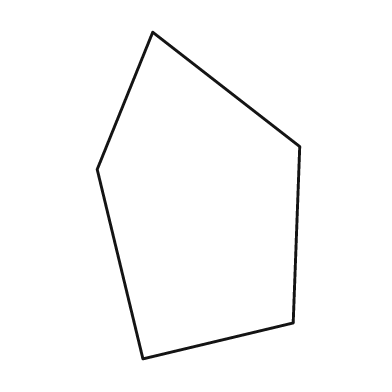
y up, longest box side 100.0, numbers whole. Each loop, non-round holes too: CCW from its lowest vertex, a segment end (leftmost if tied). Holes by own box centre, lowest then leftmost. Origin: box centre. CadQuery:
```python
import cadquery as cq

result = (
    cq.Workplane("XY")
    .moveTo(-17.0, -50.0)
    .lineTo(29.0, -39.0)
    .lineTo(31.0, 15.0)
    .lineTo(-14.0, 50.0)
    .lineTo(-31.0, 8.0)
    .close()
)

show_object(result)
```